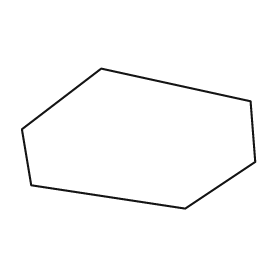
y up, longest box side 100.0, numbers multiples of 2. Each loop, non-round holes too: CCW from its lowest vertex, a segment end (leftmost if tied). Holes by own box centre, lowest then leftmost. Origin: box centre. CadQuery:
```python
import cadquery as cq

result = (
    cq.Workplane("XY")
    .moveTo(20.0, -30.0)
    .lineTo(50.0, -10.0)
    .lineTo(48.0, 16.0)
    .lineTo(-16.0, 30.0)
    .lineTo(-50.0, 4.0)
    .lineTo(-46.0, -20.0)
    .close()
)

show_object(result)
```